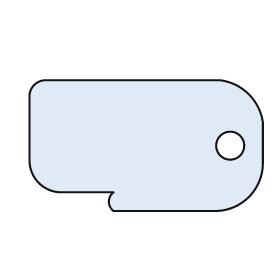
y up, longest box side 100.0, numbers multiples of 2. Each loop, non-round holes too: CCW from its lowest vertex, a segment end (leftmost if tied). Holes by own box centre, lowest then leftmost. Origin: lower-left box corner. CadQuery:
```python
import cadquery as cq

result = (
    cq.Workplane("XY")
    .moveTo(36.0, 0.0)
    .lineTo(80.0, 0.0)
    .threePointArc((94.0, 6.0), (100.0, 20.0))
    .lineTo(100.0, 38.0)
    .threePointArc((94.0, 50.0), (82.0, 56.0))
    .lineTo(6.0, 56.0)
    .threePointArc((2.0, 54.0), (0.0, 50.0))
    .lineTo(0.0, 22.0)
    .threePointArc((4.0, 12.0), (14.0, 8.0))
    .lineTo(36.0, 8.0)
    .threePointArc((34.0, 4.0), (36.0, 0.0))
    .close()
    .moveTo(86.0, 28.0)
    .circle(6.0)
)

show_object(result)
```